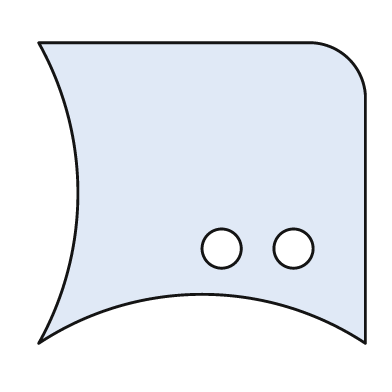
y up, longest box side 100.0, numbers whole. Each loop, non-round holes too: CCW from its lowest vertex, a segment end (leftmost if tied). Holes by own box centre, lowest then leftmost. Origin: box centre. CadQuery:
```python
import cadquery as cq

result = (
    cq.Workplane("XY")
    .moveTo(-50.0, -46.0)
    .threePointArc((0.0, -31.0), (50.0, -46.0))
    .lineTo(50.0, 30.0)
    .threePointArc((45.0, 41.0), (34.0, 46.0))
    .lineTo(-50.0, 46.0)
    .threePointArc((-38.0, 0.0), (-50.0, -46.0))
    .close()
    .moveTo(6.0, -17.0)
    .circle(6.0)
    .moveTo(28.0, -17.0)
    .circle(6.0)
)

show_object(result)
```